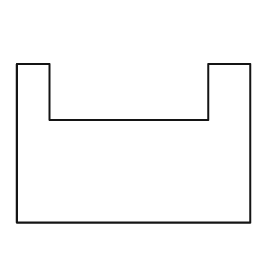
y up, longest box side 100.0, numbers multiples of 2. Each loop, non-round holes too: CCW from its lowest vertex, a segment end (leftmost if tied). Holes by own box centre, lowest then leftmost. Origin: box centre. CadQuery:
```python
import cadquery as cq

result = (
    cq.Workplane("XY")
    .moveTo(-50.0, -34.0)
    .lineTo(50.0, -34.0)
    .lineTo(50.0, 34.0)
    .lineTo(32.0, 34.0)
    .lineTo(32.0, 10.0)
    .lineTo(-36.0, 10.0)
    .lineTo(-36.0, 34.0)
    .lineTo(-50.0, 34.0)
    .close()
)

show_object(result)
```